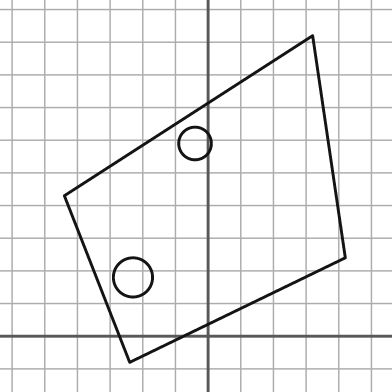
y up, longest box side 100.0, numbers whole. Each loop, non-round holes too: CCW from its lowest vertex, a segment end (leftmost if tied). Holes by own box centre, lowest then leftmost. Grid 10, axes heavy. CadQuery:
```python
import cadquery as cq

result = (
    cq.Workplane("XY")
    .moveTo(-24.0, -8.0)
    .lineTo(42.0, 24.0)
    .lineTo(32.0, 92.0)
    .lineTo(-44.0, 43.0)
    .close()
    .moveTo(-23.0, 18.0)
    .circle(6.0)
    .moveTo(-4.0, 59.0)
    .circle(5.0)
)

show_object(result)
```